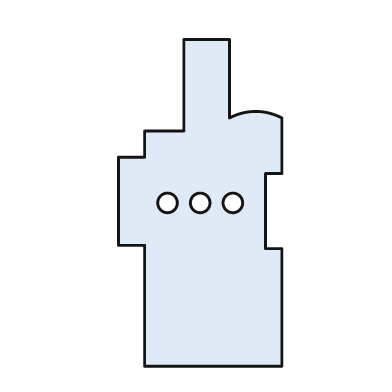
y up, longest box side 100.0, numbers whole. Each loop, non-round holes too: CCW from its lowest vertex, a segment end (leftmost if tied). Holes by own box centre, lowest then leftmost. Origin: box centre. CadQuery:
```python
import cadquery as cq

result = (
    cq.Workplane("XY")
    .moveTo(-17.0, -50.0)
    .lineTo(25.0, -50.0)
    .lineTo(25.0, -14.0)
    .lineTo(20.0, -14.0)
    .lineTo(20.0, 9.0)
    .lineTo(25.0, 9.0)
    .lineTo(25.0, 26.0)
    .threePointArc((17.0, 28.0), (9.0, 26.0))
    .lineTo(9.0, 50.0)
    .lineTo(-5.0, 50.0)
    .lineTo(-5.0, 22.0)
    .lineTo(-17.0, 22.0)
    .lineTo(-17.0, 14.0)
    .lineTo(-25.0, 14.0)
    .lineTo(-25.0, -13.0)
    .lineTo(-17.0, -13.0)
    .close()
    .moveTo(-10.0, 0.0)
    .circle(3.0)
    .moveTo(0.0, 0.0)
    .circle(3.0)
    .moveTo(10.0, 0.0)
    .circle(3.0)
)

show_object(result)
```